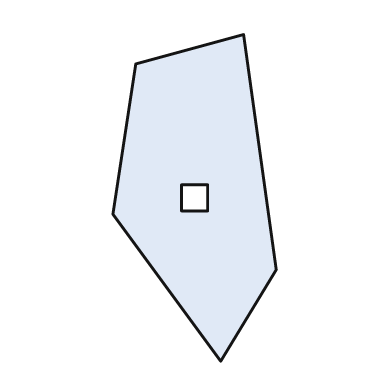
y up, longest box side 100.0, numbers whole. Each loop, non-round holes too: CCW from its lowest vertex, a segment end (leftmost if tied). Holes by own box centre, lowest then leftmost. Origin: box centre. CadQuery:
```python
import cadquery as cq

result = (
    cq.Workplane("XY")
    .moveTo(8.0, -50.0)
    .lineTo(25.0, -22.0)
    .lineTo(15.0, 50.0)
    .lineTo(-18.0, 41.0)
    .lineTo(-25.0, -5.0)
    .close()
    .moveTo(-4.0, -4.0)
    .lineTo(4.0, -4.0)
    .lineTo(4.0, 4.0)
    .lineTo(-4.0, 4.0)
    .close()
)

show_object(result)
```